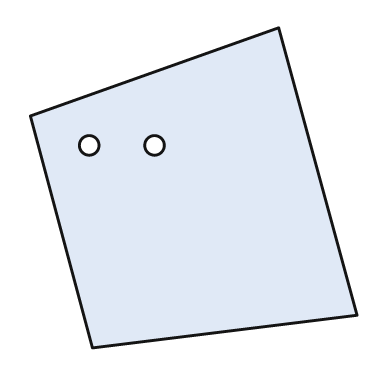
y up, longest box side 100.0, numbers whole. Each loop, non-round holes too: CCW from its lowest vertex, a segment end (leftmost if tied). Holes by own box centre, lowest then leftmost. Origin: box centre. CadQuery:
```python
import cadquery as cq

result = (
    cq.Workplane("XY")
    .moveTo(-31.0, -49.0)
    .lineTo(50.0, -39.0)
    .lineTo(26.0, 49.0)
    .lineTo(-50.0, 22.0)
    .close()
    .moveTo(-32.0, 13.0)
    .circle(3.0)
    .moveTo(-12.0, 13.0)
    .circle(3.0)
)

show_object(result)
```